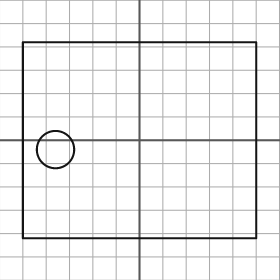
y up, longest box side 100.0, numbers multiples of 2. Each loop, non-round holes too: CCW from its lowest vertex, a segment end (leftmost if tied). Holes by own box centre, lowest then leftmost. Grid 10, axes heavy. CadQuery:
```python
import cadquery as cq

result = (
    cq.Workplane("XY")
    .moveTo(-50.0, -42.0)
    .lineTo(50.0, -42.0)
    .lineTo(50.0, 42.0)
    .lineTo(-50.0, 42.0)
    .close()
    .moveTo(-36.0, -4.0)
    .circle(8.0)
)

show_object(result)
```